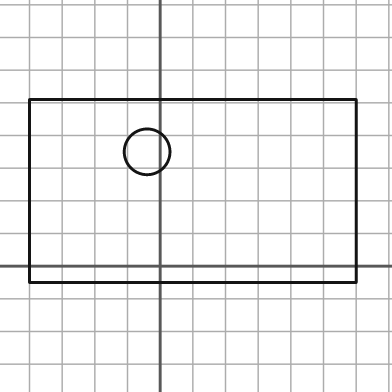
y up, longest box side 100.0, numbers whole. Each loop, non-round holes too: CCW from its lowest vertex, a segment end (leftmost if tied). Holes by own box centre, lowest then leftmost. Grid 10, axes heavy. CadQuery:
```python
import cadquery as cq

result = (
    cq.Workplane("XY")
    .moveTo(-40.0, -5.0)
    .lineTo(60.0, -5.0)
    .lineTo(60.0, 51.0)
    .lineTo(-40.0, 51.0)
    .close()
    .moveTo(-4.0, 35.0)
    .circle(7.0)
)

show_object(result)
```